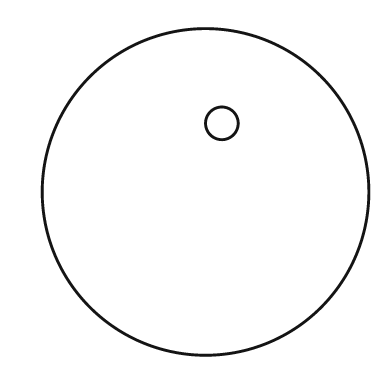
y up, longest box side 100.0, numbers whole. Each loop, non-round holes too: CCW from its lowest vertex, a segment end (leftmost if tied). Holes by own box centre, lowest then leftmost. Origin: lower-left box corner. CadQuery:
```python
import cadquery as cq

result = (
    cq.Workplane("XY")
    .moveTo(50.0, 50.0)
    .circle(50.0)
    .moveTo(55.0, 71.0)
    .circle(5.0)
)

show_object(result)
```